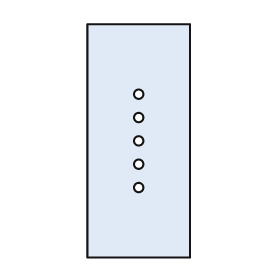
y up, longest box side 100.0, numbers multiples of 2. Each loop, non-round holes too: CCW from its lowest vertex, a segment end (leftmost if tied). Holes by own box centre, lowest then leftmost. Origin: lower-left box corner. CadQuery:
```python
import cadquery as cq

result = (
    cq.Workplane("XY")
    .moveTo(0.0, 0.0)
    .lineTo(44.0, 0.0)
    .lineTo(44.0, 100.0)
    .lineTo(0.0, 100.0)
    .close()
    .moveTo(22.0, 30.0)
    .circle(2.0)
    .moveTo(22.0, 40.0)
    .circle(2.0)
    .moveTo(22.0, 50.0)
    .circle(2.0)
    .moveTo(22.0, 60.0)
    .circle(2.0)
    .moveTo(22.0, 70.0)
    .circle(2.0)
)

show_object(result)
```